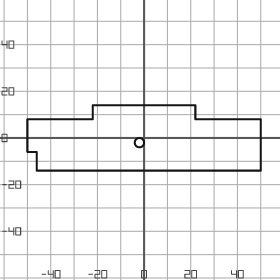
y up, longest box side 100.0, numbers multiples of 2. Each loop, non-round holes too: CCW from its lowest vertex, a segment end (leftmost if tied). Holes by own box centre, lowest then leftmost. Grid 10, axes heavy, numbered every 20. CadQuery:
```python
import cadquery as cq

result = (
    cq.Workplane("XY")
    .moveTo(-46.0, -14.0)
    .lineTo(50.0, -14.0)
    .lineTo(50.0, 8.0)
    .lineTo(22.0, 8.0)
    .lineTo(22.0, 14.0)
    .lineTo(-22.0, 14.0)
    .lineTo(-22.0, 8.0)
    .lineTo(-50.0, 8.0)
    .lineTo(-50.0, -6.0)
    .lineTo(-46.0, -6.0)
    .close()
    .moveTo(-2.0, -2.0)
    .circle(2.0)
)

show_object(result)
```